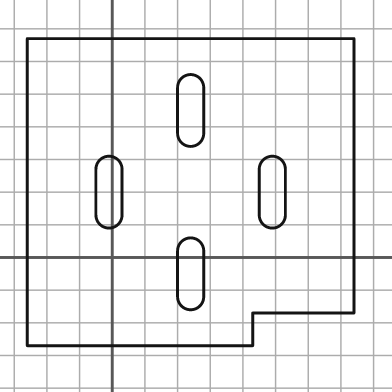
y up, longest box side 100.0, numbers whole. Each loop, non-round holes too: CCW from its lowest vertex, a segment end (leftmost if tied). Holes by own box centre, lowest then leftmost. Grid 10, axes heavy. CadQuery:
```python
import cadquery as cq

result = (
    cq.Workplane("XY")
    .moveTo(-26.0, -27.0)
    .lineTo(43.0, -27.0)
    .lineTo(43.0, -17.0)
    .lineTo(74.0, -17.0)
    .lineTo(74.0, 67.0)
    .lineTo(-26.0, 67.0)
    .close()
    .moveTo(20.0, -12.0)
    .threePointArc((24.0, -16.0), (28.0, -12.0))
    .lineTo(28.0, 2.0)
    .threePointArc((24.0, 6.0), (20.0, 2.0))
    .close()
    .moveTo(-5.0, 13.0)
    .threePointArc((-1.0, 9.0), (3.0, 13.0))
    .lineTo(3.0, 27.0)
    .threePointArc((-1.0, 31.0), (-5.0, 27.0))
    .close()
    .moveTo(45.0, 13.0)
    .threePointArc((49.0, 9.0), (53.0, 13.0))
    .lineTo(53.0, 27.0)
    .threePointArc((49.0, 31.0), (45.0, 27.0))
    .close()
    .moveTo(20.0, 38.0)
    .threePointArc((24.0, 34.0), (28.0, 38.0))
    .lineTo(28.0, 52.0)
    .threePointArc((24.0, 56.0), (20.0, 52.0))
    .close()
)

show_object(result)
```